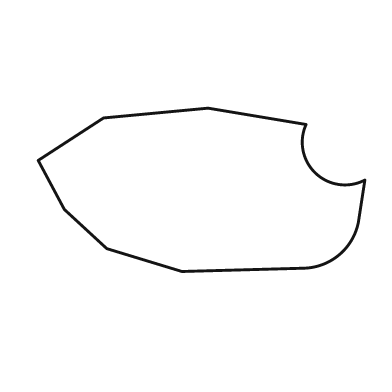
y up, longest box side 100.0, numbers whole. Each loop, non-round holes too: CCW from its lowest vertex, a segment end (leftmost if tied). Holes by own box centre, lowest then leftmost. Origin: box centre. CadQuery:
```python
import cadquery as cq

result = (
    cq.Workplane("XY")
    .moveTo(-6.0, -25.0)
    .lineTo(31.0, -24.0)
    .threePointArc((42.0, -20.0), (48.0, -10.0))
    .lineTo(50.0, 3.0)
    .threePointArc((35.0, 5.0), (32.0, 20.0))
    .lineTo(2.0, 25.0)
    .lineTo(-30.0, 22.0)
    .lineTo(-50.0, 9.0)
    .lineTo(-42.0, -6.0)
    .lineTo(-29.0, -18.0)
    .close()
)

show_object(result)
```